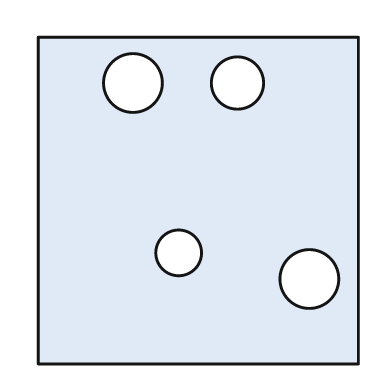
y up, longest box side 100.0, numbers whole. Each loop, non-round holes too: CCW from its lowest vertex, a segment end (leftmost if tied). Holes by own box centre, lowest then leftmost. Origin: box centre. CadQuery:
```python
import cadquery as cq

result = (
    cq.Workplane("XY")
    .moveTo(-49.0, -50.0)
    .lineTo(49.0, -50.0)
    .lineTo(49.0, 50.0)
    .lineTo(-49.0, 50.0)
    .close()
    .moveTo(34.0, -24.0)
    .circle(9.0)
    .moveTo(-6.0, -16.0)
    .circle(7.0)
    .moveTo(-20.0, 36.0)
    .circle(9.0)
    .moveTo(12.0, 36.0)
    .circle(8.0)
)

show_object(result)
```